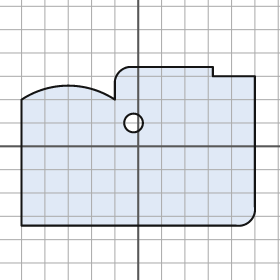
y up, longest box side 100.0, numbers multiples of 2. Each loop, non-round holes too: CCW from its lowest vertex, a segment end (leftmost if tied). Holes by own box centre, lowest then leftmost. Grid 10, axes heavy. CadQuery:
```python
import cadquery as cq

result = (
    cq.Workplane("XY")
    .moveTo(-50.0, -34.0)
    .lineTo(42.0, -34.0)
    .threePointArc((48.0, -32.0), (50.0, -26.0))
    .lineTo(50.0, 30.0)
    .lineTo(32.0, 30.0)
    .lineTo(32.0, 34.0)
    .lineTo(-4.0, 34.0)
    .threePointArc((-8.0, 32.0), (-10.0, 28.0))
    .lineTo(-10.0, 20.0)
    .threePointArc((-30.0, 26.0), (-50.0, 20.0))
    .close()
    .moveTo(-2.0, 10.0)
    .circle(4.0)
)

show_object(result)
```